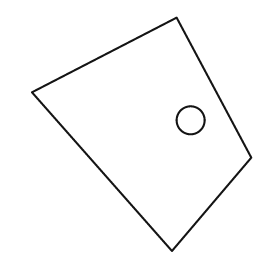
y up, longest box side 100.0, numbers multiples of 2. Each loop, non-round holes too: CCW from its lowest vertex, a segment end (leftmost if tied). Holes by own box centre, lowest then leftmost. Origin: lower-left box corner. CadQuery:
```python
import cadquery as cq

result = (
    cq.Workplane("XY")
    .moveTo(60.0, 0.0)
    .lineTo(94.0, 40.0)
    .lineTo(62.0, 100.0)
    .lineTo(0.0, 68.0)
    .close()
    .moveTo(68.0, 56.0)
    .circle(6.0)
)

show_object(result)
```